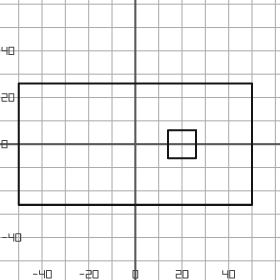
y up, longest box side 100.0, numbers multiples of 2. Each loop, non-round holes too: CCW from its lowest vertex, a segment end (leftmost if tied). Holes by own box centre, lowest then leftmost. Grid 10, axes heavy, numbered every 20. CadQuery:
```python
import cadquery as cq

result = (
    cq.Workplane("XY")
    .moveTo(-50.0, -26.0)
    .lineTo(50.0, -26.0)
    .lineTo(50.0, 26.0)
    .lineTo(-50.0, 26.0)
    .close()
    .moveTo(14.0, -6.0)
    .lineTo(26.0, -6.0)
    .lineTo(26.0, 6.0)
    .lineTo(14.0, 6.0)
    .close()
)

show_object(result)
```